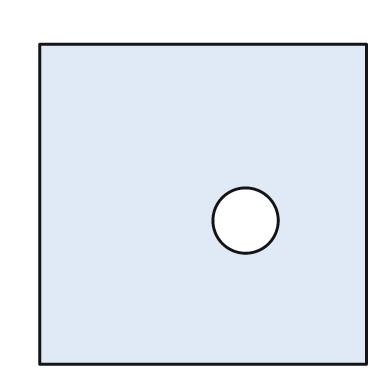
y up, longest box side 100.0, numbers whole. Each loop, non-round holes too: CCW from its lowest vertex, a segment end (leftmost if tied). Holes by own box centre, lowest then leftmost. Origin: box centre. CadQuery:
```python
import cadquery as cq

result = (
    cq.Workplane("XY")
    .moveTo(-50.0, -49.0)
    .lineTo(50.0, -49.0)
    .lineTo(50.0, 49.0)
    .lineTo(-50.0, 49.0)
    .close()
    .moveTo(13.0, -5.0)
    .circle(10.0)
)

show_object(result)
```